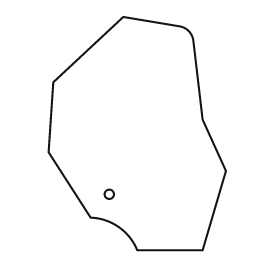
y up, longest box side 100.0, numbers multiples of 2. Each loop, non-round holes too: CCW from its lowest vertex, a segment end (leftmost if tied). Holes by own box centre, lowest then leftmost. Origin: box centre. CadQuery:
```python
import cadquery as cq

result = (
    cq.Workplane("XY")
    .moveTo(0.0, -50.0)
    .lineTo(28.0, -50.0)
    .lineTo(38.0, -16.0)
    .lineTo(28.0, 6.0)
    .lineTo(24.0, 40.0)
    .threePointArc((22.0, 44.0), (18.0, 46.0))
    .lineTo(-6.0, 50.0)
    .lineTo(-36.0, 22.0)
    .lineTo(-38.0, -8.0)
    .lineTo(-20.0, -36.0)
    .threePointArc((-8.0, -40.0), (0.0, -50.0))
    .close()
    .moveTo(-12.0, -26.0)
    .circle(2.0)
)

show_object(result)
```